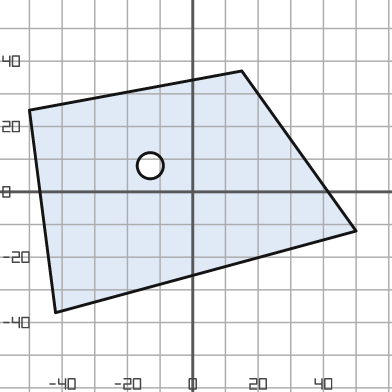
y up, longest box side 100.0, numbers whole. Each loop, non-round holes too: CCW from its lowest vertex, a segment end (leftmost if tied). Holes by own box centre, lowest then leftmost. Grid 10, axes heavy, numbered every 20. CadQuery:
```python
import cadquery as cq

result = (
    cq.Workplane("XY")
    .moveTo(-42.0, -37.0)
    .lineTo(50.0, -12.0)
    .lineTo(15.0, 37.0)
    .lineTo(-50.0, 25.0)
    .close()
    .moveTo(-13.0, 8.0)
    .circle(4.0)
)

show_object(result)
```